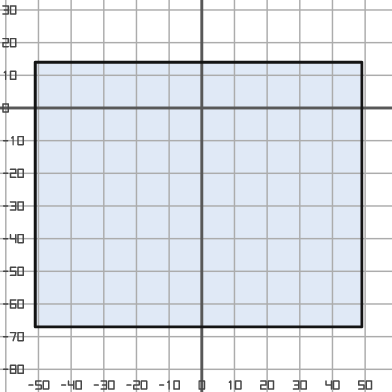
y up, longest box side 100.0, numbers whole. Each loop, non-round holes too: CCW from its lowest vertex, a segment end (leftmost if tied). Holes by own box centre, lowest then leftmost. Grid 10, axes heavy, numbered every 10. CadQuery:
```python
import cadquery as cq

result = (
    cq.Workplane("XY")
    .moveTo(-51.0, -67.0)
    .lineTo(49.0, -67.0)
    .lineTo(49.0, 14.0)
    .lineTo(-51.0, 14.0)
    .close()
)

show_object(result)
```